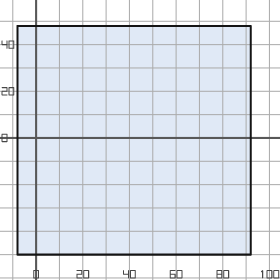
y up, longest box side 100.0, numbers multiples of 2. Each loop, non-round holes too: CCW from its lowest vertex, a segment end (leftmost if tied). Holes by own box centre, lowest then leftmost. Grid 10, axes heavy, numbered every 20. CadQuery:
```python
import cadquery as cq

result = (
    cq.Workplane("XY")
    .moveTo(-8.0, -50.0)
    .lineTo(92.0, -50.0)
    .lineTo(92.0, 48.0)
    .lineTo(-8.0, 48.0)
    .close()
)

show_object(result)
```